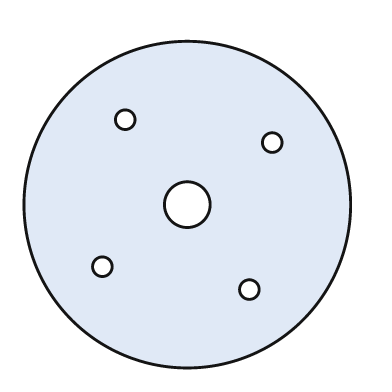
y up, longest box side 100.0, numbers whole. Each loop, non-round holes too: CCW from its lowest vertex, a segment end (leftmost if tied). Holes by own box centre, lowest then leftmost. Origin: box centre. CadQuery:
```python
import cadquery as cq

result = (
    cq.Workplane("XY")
    .moveTo(0.0, 0.0)
    .circle(50.0)
    .moveTo(19.0, -26.0)
    .circle(3.0)
    .moveTo(-26.0, -19.0)
    .circle(3.0)
    .moveTo(0.0, 0.0)
    .circle(7.0)
    .moveTo(26.0, 19.0)
    .circle(3.0)
    .moveTo(-19.0, 26.0)
    .circle(3.0)
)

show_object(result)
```